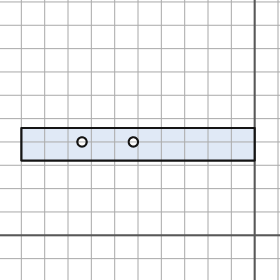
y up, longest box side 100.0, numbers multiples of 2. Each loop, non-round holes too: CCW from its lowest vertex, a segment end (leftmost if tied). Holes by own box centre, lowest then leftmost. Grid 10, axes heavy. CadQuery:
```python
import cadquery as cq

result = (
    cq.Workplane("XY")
    .moveTo(-100.0, 32.0)
    .lineTo(0.0, 32.0)
    .lineTo(0.0, 46.0)
    .lineTo(-100.0, 46.0)
    .close()
    .moveTo(-74.0, 40.0)
    .circle(2.0)
    .moveTo(-52.0, 40.0)
    .circle(2.0)
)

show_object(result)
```